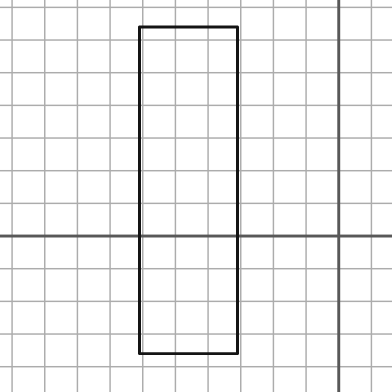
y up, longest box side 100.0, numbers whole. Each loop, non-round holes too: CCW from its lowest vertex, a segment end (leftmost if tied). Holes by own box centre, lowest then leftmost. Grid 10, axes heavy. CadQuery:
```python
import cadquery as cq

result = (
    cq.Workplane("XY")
    .moveTo(-61.0, -36.0)
    .lineTo(-31.0, -36.0)
    .lineTo(-31.0, 64.0)
    .lineTo(-61.0, 64.0)
    .close()
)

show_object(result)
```